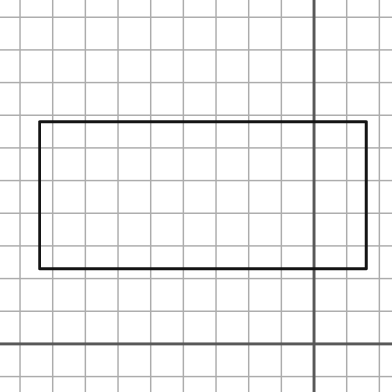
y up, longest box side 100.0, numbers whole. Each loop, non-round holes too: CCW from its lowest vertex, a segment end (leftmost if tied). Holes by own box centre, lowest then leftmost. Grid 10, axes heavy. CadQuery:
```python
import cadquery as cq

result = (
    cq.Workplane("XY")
    .moveTo(-84.0, 23.0)
    .lineTo(16.0, 23.0)
    .lineTo(16.0, 68.0)
    .lineTo(-84.0, 68.0)
    .close()
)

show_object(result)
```